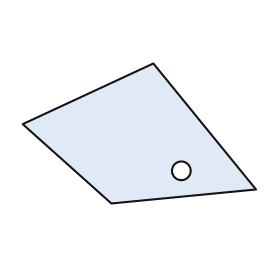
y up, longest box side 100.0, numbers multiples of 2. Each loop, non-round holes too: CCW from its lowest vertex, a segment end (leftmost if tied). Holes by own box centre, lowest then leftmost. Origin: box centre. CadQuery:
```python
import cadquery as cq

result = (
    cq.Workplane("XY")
    .moveTo(-12.0, -30.0)
    .lineTo(50.0, -24.0)
    .lineTo(6.0, 30.0)
    .lineTo(-50.0, 4.0)
    .close()
    .moveTo(18.0, -16.0)
    .circle(4.0)
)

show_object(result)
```